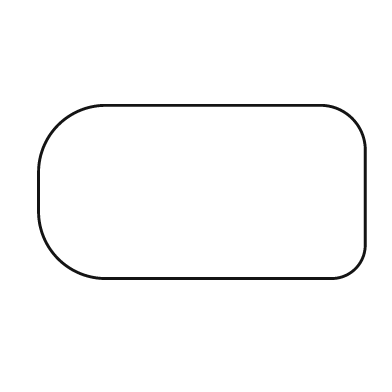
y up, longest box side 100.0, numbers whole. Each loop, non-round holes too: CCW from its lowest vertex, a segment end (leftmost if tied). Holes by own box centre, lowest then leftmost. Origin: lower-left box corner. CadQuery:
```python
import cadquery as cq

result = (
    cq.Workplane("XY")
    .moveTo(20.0, 0.0)
    .lineTo(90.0, 0.0)
    .threePointArc((97.0, 3.0), (100.0, 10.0))
    .lineTo(100.0, 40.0)
    .threePointArc((96.0, 49.0), (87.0, 53.0))
    .lineTo(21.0, 53.0)
    .threePointArc((6.0, 47.0), (0.0, 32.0))
    .lineTo(0.0, 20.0)
    .threePointArc((6.0, 6.0), (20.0, 0.0))
    .close()
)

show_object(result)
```